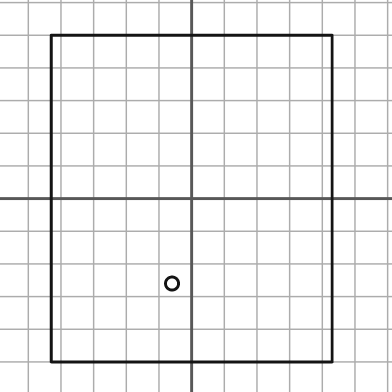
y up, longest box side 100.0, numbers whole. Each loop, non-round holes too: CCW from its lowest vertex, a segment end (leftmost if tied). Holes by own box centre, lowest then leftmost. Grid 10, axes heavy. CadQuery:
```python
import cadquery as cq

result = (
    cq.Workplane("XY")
    .moveTo(-43.0, -50.0)
    .lineTo(43.0, -50.0)
    .lineTo(43.0, 50.0)
    .lineTo(-43.0, 50.0)
    .close()
    .moveTo(-6.0, -26.0)
    .circle(2.0)
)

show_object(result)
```